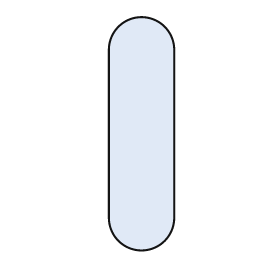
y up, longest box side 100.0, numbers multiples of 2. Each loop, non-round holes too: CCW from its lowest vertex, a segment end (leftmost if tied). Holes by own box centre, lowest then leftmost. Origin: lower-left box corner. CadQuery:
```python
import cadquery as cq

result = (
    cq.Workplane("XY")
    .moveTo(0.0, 14.0)
    .threePointArc((14.0, 0.0), (28.0, 14.0))
    .lineTo(28.0, 86.0)
    .threePointArc((14.0, 100.0), (0.0, 86.0))
    .close()
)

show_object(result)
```